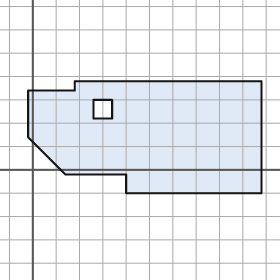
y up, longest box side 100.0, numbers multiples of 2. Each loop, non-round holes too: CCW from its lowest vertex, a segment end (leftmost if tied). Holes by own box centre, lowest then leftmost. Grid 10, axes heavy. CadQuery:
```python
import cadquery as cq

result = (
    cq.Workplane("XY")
    .moveTo(40.0, -10.0)
    .lineTo(98.0, -10.0)
    .lineTo(98.0, 38.0)
    .lineTo(18.0, 38.0)
    .lineTo(18.0, 34.0)
    .lineTo(-2.0, 34.0)
    .lineTo(-2.0, 14.0)
    .lineTo(14.0, -2.0)
    .lineTo(40.0, -2.0)
    .close()
    .moveTo(26.0, 22.0)
    .lineTo(34.0, 22.0)
    .lineTo(34.0, 30.0)
    .lineTo(26.0, 30.0)
    .close()
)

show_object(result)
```